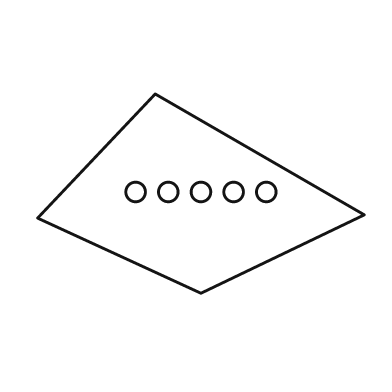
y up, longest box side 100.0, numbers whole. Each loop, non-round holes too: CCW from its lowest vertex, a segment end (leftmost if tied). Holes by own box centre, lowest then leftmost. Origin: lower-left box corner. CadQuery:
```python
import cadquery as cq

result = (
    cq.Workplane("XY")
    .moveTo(50.0, 0.0)
    .lineTo(100.0, 24.0)
    .lineTo(36.0, 61.0)
    .lineTo(0.0, 23.0)
    .close()
    .moveTo(30.0, 31.0)
    .circle(3.0)
    .moveTo(40.0, 31.0)
    .circle(3.0)
    .moveTo(50.0, 31.0)
    .circle(3.0)
    .moveTo(60.0, 31.0)
    .circle(3.0)
    .moveTo(70.0, 31.0)
    .circle(3.0)
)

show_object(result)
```